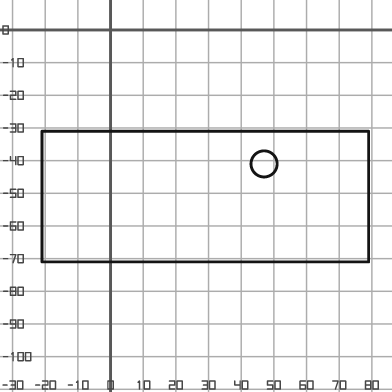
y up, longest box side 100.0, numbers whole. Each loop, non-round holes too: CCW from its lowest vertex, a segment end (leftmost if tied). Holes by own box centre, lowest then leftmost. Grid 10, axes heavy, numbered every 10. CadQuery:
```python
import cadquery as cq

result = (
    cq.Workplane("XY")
    .moveTo(-21.0, -71.0)
    .lineTo(79.0, -71.0)
    .lineTo(79.0, -31.0)
    .lineTo(-21.0, -31.0)
    .close()
    .moveTo(47.0, -41.0)
    .circle(4.0)
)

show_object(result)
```